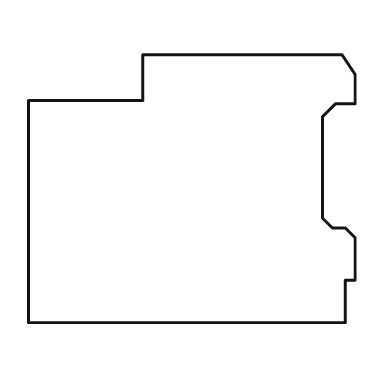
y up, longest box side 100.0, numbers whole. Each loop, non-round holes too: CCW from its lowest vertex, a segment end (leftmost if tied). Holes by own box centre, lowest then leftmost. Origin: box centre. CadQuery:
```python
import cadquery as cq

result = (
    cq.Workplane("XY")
    .moveTo(-50.0, -41.0)
    .lineTo(47.0, -41.0)
    .lineTo(47.0, -28.0)
    .lineTo(50.0, -28.0)
    .lineTo(50.0, -15.0)
    .lineTo(47.0, -12.0)
    .lineTo(43.0, -12.0)
    .lineTo(40.0, -9.0)
    .lineTo(40.0, 22.0)
    .lineTo(44.0, 26.0)
    .lineTo(50.0, 26.0)
    .lineTo(50.0, 35.0)
    .lineTo(46.0, 41.0)
    .lineTo(-15.0, 41.0)
    .lineTo(-15.0, 27.0)
    .lineTo(-50.0, 27.0)
    .close()
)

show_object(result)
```